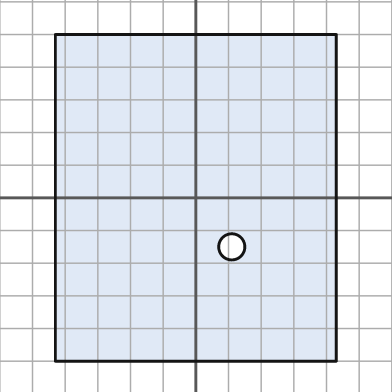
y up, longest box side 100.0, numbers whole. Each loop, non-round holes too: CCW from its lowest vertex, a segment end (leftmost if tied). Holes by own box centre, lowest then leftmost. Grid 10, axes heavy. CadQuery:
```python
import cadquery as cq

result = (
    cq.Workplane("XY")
    .moveTo(-43.0, -50.0)
    .lineTo(43.0, -50.0)
    .lineTo(43.0, 50.0)
    .lineTo(-43.0, 50.0)
    .close()
    .moveTo(11.0, -15.0)
    .circle(4.0)
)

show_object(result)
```